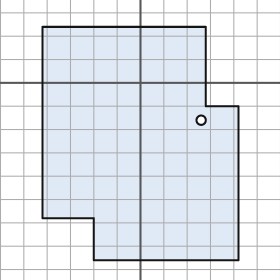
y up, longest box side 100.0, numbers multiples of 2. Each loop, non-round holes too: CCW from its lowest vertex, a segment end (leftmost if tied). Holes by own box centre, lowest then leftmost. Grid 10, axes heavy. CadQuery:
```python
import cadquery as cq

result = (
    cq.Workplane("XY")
    .moveTo(-20.0, -76.0)
    .lineTo(42.0, -76.0)
    .lineTo(42.0, -10.0)
    .lineTo(28.0, -10.0)
    .lineTo(28.0, 24.0)
    .lineTo(-42.0, 24.0)
    .lineTo(-42.0, -58.0)
    .lineTo(-20.0, -58.0)
    .close()
    .moveTo(26.0, -16.0)
    .circle(2.0)
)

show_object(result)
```